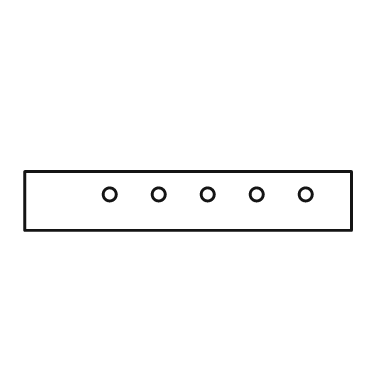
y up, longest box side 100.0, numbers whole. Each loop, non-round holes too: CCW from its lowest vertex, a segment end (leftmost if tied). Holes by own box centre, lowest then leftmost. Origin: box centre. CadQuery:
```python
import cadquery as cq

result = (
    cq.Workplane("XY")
    .moveTo(-50.0, -9.0)
    .lineTo(50.0, -9.0)
    .lineTo(50.0, 9.0)
    .lineTo(-50.0, 9.0)
    .close()
    .moveTo(-24.0, 2.0)
    .circle(2.0)
    .moveTo(-9.0, 2.0)
    .circle(2.0)
    .moveTo(6.0, 2.0)
    .circle(2.0)
    .moveTo(21.0, 2.0)
    .circle(2.0)
    .moveTo(36.0, 2.0)
    .circle(2.0)
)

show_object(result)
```